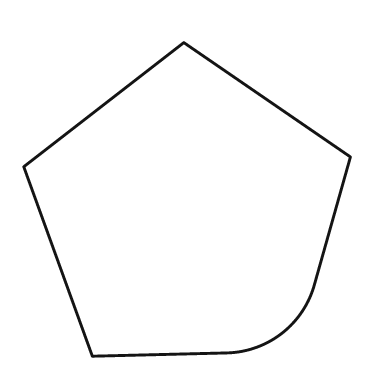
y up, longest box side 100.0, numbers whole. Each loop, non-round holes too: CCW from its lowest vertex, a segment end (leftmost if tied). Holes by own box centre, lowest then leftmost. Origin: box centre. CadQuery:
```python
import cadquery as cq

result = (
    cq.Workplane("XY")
    .moveTo(-29.0, -48.0)
    .lineTo(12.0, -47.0)
    .threePointArc((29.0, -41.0), (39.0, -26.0))
    .lineTo(50.0, 13.0)
    .lineTo(-1.0, 48.0)
    .lineTo(-50.0, 10.0)
    .close()
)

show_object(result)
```